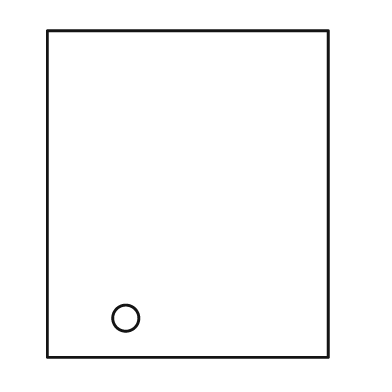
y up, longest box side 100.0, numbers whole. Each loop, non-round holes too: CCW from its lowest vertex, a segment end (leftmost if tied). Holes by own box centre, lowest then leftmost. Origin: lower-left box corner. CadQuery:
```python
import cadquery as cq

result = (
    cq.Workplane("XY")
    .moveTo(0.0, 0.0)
    .lineTo(86.0, 0.0)
    .lineTo(86.0, 100.0)
    .lineTo(0.0, 100.0)
    .close()
    .moveTo(24.0, 12.0)
    .circle(4.0)
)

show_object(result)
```